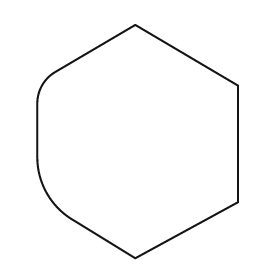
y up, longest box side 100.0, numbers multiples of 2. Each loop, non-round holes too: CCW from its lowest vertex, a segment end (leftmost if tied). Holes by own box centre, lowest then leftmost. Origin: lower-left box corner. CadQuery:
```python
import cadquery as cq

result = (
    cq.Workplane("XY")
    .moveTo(42.0, 0.0)
    .lineTo(86.0, 24.0)
    .lineTo(86.0, 74.0)
    .lineTo(42.0, 100.0)
    .lineTo(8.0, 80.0)
    .threePointArc((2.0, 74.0), (0.0, 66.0))
    .lineTo(0.0, 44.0)
    .threePointArc((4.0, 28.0), (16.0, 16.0))
    .close()
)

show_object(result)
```